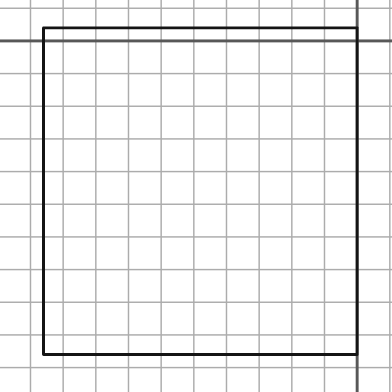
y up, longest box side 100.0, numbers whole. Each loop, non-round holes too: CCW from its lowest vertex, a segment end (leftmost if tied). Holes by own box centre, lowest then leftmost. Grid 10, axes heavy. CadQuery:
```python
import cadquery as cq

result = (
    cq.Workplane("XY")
    .moveTo(-96.0, -96.0)
    .lineTo(0.0, -96.0)
    .lineTo(0.0, 4.0)
    .lineTo(-96.0, 4.0)
    .close()
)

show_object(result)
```